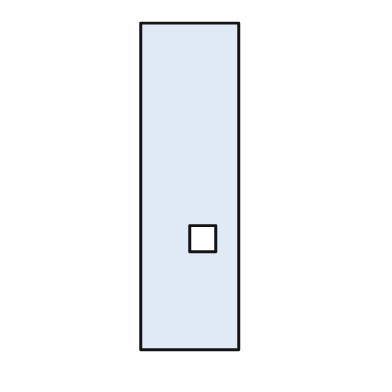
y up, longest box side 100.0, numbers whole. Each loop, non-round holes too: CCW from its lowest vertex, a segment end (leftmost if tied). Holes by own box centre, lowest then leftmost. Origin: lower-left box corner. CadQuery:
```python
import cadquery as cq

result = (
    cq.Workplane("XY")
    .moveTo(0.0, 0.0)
    .lineTo(30.0, 0.0)
    .lineTo(30.0, 100.0)
    .lineTo(0.0, 100.0)
    .close()
    .moveTo(15.0, 30.0)
    .lineTo(23.0, 30.0)
    .lineTo(23.0, 38.0)
    .lineTo(15.0, 38.0)
    .close()
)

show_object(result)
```